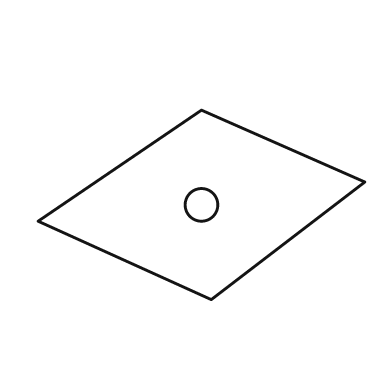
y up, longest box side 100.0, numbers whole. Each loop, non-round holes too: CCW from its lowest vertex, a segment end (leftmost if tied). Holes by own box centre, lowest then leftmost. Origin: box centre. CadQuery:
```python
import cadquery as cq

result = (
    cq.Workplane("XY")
    .moveTo(3.0, -29.0)
    .lineTo(50.0, 7.0)
    .lineTo(0.0, 29.0)
    .lineTo(-50.0, -5.0)
    .close()
    .moveTo(0.0, 0.0)
    .circle(5.0)
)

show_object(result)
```